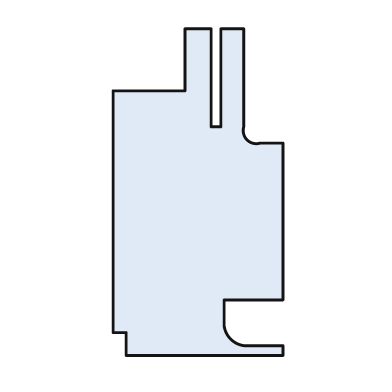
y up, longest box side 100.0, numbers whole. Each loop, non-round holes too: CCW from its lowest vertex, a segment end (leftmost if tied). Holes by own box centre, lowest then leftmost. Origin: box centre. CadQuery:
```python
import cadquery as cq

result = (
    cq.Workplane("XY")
    .moveTo(-22.0, -50.0)
    .lineTo(26.0, -50.0)
    .lineTo(26.0, -47.0)
    .lineTo(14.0, -47.0)
    .threePointArc((10.0, -45.0), (8.0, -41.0))
    .lineTo(8.0, -33.0)
    .lineTo(26.0, -33.0)
    .lineTo(26.0, 15.0)
    .lineTo(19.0, 15.0)
    .threePointArc((15.0, 16.0), (14.0, 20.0))
    .lineTo(14.0, 50.0)
    .lineTo(7.0, 50.0)
    .lineTo(7.0, 20.0)
    .lineTo(4.0, 20.0)
    .lineTo(4.0, 50.0)
    .lineTo(-4.0, 50.0)
    .lineTo(-4.0, 31.0)
    .lineTo(-26.0, 31.0)
    .lineTo(-26.0, -43.0)
    .lineTo(-22.0, -43.0)
    .close()
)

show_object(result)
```